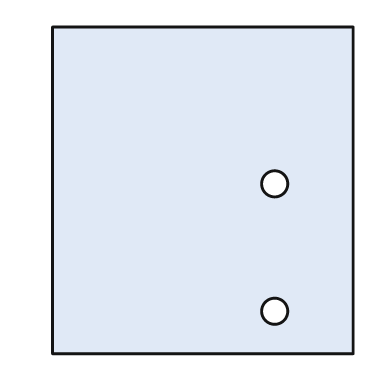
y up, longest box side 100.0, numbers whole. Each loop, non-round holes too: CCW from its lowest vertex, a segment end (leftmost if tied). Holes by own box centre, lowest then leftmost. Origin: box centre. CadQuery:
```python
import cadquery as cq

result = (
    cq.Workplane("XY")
    .moveTo(-46.0, -50.0)
    .lineTo(46.0, -50.0)
    .lineTo(46.0, 50.0)
    .lineTo(-46.0, 50.0)
    .close()
    .moveTo(22.0, -37.0)
    .circle(4.0)
    .moveTo(22.0, 2.0)
    .circle(4.0)
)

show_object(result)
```